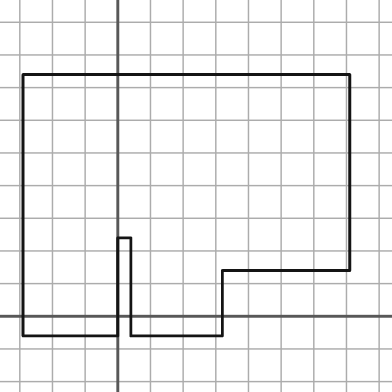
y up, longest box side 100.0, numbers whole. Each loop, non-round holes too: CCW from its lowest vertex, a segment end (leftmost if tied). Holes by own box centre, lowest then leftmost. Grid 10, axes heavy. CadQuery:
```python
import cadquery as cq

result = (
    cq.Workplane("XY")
    .moveTo(-29.0, -6.0)
    .lineTo(0.0, -6.0)
    .lineTo(0.0, 24.0)
    .lineTo(4.0, 24.0)
    .lineTo(4.0, -6.0)
    .lineTo(32.0, -6.0)
    .lineTo(32.0, 14.0)
    .lineTo(71.0, 14.0)
    .lineTo(71.0, 74.0)
    .lineTo(-29.0, 74.0)
    .close()
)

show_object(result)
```